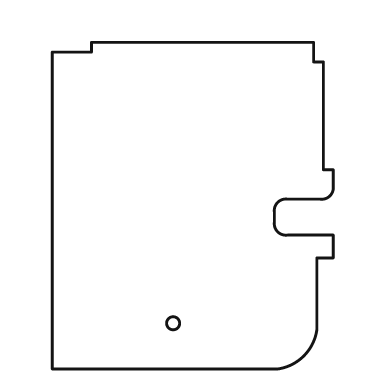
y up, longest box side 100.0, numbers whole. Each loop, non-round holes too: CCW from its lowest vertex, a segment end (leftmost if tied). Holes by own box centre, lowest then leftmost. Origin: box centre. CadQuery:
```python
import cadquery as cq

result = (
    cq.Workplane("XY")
    .moveTo(-43.0, -50.0)
    .lineTo(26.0, -50.0)
    .threePointArc((34.0, -46.0), (38.0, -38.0))
    .lineTo(38.0, -16.0)
    .lineTo(43.0, -16.0)
    .lineTo(43.0, -9.0)
    .lineTo(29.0, -9.0)
    .threePointArc((26.0, -8.0), (25.0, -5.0))
    .lineTo(25.0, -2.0)
    .threePointArc((26.0, 1.0), (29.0, 2.0))
    .lineTo(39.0, 2.0)
    .threePointArc((42.0, 3.0), (43.0, 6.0))
    .lineTo(43.0, 11.0)
    .lineTo(40.0, 11.0)
    .lineTo(40.0, 44.0)
    .lineTo(37.0, 44.0)
    .lineTo(37.0, 50.0)
    .lineTo(-31.0, 50.0)
    .lineTo(-31.0, 47.0)
    .lineTo(-43.0, 47.0)
    .close()
    .moveTo(-6.0, -36.0)
    .circle(2.0)
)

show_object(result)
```